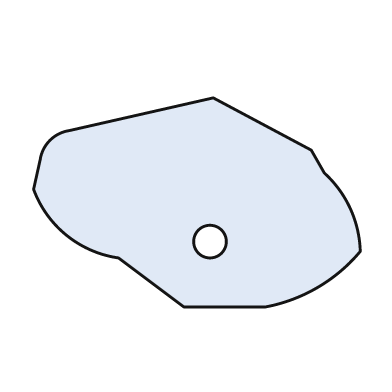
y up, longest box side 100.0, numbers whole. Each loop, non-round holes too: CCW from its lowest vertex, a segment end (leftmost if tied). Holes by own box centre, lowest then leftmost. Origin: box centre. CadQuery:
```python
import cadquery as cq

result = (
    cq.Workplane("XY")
    .moveTo(-4.0, -32.0)
    .lineTo(21.0, -32.0)
    .threePointArc((37.0, -26.0), (50.0, -15.0))
    .threePointArc((47.0, -2.0), (39.0, 9.0))
    .lineTo(35.0, 16.0)
    .lineTo(5.0, 32.0)
    .lineTo(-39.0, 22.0)
    .threePointArc((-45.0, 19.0), (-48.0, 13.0))
    .lineTo(-50.0, 4.0)
    .threePointArc((-40.0, -10.0), (-24.0, -17.0))
    .close()
    .moveTo(4.0, -12.0)
    .circle(5.0)
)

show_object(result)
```